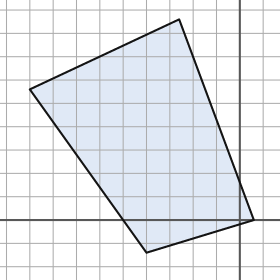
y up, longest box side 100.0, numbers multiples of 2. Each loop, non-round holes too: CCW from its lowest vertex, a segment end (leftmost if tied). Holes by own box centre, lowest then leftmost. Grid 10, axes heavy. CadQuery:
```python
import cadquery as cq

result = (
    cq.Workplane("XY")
    .moveTo(-40.0, -14.0)
    .lineTo(6.0, 0.0)
    .lineTo(-26.0, 86.0)
    .lineTo(-90.0, 56.0)
    .close()
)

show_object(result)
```